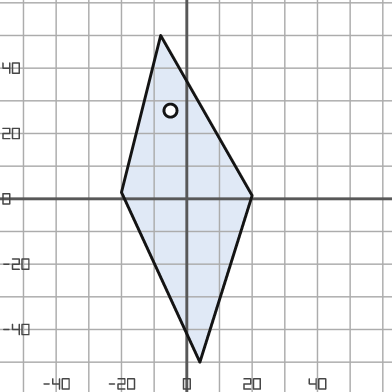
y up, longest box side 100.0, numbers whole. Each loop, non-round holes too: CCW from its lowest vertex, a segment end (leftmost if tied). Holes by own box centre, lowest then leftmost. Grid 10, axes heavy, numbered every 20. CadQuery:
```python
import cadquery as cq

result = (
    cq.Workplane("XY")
    .moveTo(4.0, -50.0)
    .lineTo(20.0, 1.0)
    .lineTo(-8.0, 50.0)
    .lineTo(-20.0, 2.0)
    .close()
    .moveTo(-5.0, 27.0)
    .circle(2.0)
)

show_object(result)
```